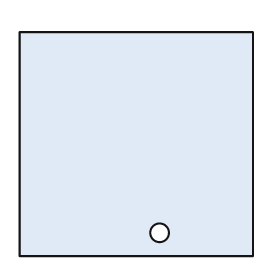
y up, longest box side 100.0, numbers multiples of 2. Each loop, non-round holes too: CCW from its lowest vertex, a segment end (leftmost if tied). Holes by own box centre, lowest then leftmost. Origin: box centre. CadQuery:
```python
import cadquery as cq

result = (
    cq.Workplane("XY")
    .moveTo(-50.0, -48.0)
    .lineTo(50.0, -48.0)
    .lineTo(50.0, 48.0)
    .lineTo(-50.0, 48.0)
    .close()
    .moveTo(10.0, -38.0)
    .circle(4.0)
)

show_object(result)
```